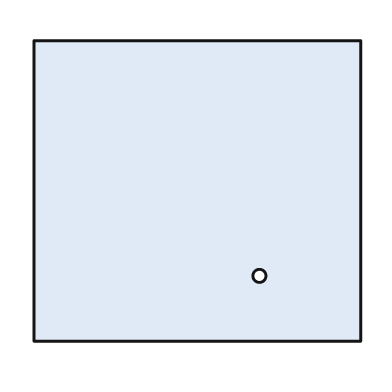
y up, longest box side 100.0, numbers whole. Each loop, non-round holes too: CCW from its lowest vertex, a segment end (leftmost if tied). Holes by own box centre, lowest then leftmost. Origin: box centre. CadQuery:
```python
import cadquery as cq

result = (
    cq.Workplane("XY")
    .moveTo(-50.0, -46.0)
    .lineTo(50.0, -46.0)
    .lineTo(50.0, 46.0)
    .lineTo(-50.0, 46.0)
    .close()
    .moveTo(19.0, -26.0)
    .circle(2.0)
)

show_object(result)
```